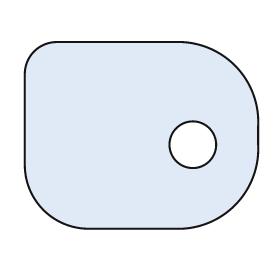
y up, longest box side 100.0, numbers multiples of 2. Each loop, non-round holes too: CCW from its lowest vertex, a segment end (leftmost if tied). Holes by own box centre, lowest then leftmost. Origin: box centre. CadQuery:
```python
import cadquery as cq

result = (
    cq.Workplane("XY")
    .moveTo(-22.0, -40.0)
    .lineTo(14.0, -40.0)
    .threePointArc((40.0, -30.0), (50.0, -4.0))
    .lineTo(50.0, 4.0)
    .threePointArc((40.0, 30.0), (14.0, 40.0))
    .lineTo(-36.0, 40.0)
    .threePointArc((-46.0, 36.0), (-50.0, 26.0))
    .lineTo(-50.0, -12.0)
    .threePointArc((-42.0, -32.0), (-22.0, -40.0))
    .close()
    .moveTo(22.0, -4.0)
    .circle(10.0)
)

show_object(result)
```